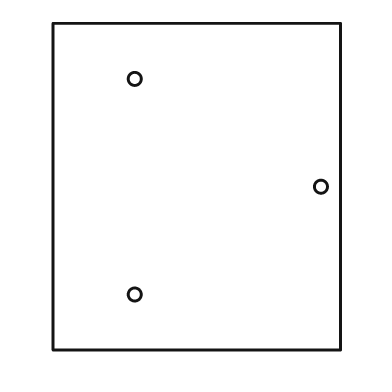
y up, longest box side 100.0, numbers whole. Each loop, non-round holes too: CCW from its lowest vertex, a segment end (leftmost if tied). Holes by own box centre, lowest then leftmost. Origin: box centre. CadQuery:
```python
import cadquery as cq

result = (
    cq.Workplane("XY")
    .moveTo(-44.0, -50.0)
    .lineTo(44.0, -50.0)
    .lineTo(44.0, 50.0)
    .lineTo(-44.0, 50.0)
    .close()
    .moveTo(-19.0, -33.0)
    .circle(2.0)
    .moveTo(38.0, 0.0)
    .circle(2.0)
    .moveTo(-19.0, 33.0)
    .circle(2.0)
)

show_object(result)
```